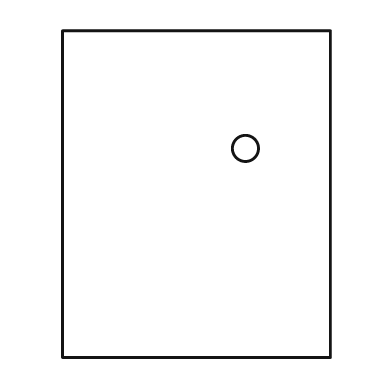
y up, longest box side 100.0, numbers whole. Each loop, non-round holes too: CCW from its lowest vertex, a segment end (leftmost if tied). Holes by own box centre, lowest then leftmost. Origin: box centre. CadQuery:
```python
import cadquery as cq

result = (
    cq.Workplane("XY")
    .moveTo(-41.0, -50.0)
    .lineTo(41.0, -50.0)
    .lineTo(41.0, 50.0)
    .lineTo(-41.0, 50.0)
    .close()
    .moveTo(15.0, 14.0)
    .circle(4.0)
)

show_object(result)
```